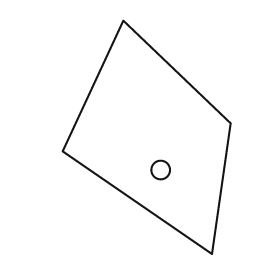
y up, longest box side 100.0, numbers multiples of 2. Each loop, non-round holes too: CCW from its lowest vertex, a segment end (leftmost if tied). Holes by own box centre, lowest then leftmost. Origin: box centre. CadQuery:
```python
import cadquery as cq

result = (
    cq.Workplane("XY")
    .moveTo(28.0, -50.0)
    .lineTo(36.0, 6.0)
    .lineTo(-10.0, 50.0)
    .lineTo(-36.0, -6.0)
    .close()
    .moveTo(6.0, -14.0)
    .circle(4.0)
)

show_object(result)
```